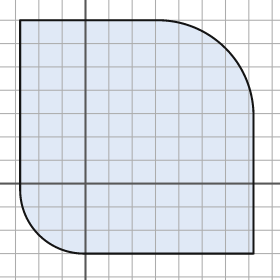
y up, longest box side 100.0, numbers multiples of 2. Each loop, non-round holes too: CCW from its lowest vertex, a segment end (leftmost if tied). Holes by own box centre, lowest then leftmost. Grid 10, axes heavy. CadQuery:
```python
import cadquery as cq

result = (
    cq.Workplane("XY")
    .moveTo(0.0, -30.0)
    .lineTo(72.0, -30.0)
    .lineTo(72.0, 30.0)
    .threePointArc((60.0, 58.0), (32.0, 70.0))
    .lineTo(-28.0, 70.0)
    .lineTo(-28.0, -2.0)
    .threePointArc((-20.0, -22.0), (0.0, -30.0))
    .close()
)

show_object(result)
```